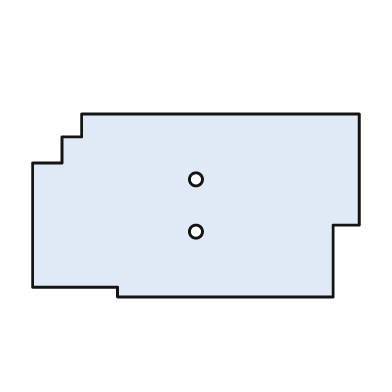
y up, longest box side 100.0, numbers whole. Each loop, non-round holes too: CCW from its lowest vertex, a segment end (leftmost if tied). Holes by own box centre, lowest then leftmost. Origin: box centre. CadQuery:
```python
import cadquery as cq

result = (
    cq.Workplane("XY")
    .moveTo(-24.0, -28.0)
    .lineTo(42.0, -28.0)
    .lineTo(42.0, -6.0)
    .lineTo(50.0, -6.0)
    .lineTo(50.0, 28.0)
    .lineTo(-35.0, 28.0)
    .lineTo(-35.0, 21.0)
    .lineTo(-41.0, 21.0)
    .lineTo(-41.0, 13.0)
    .lineTo(-50.0, 13.0)
    .lineTo(-50.0, -25.0)
    .lineTo(-24.0, -25.0)
    .close()
    .moveTo(0.0, -8.0)
    .circle(2.0)
    .moveTo(0.0, 8.0)
    .circle(2.0)
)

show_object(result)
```